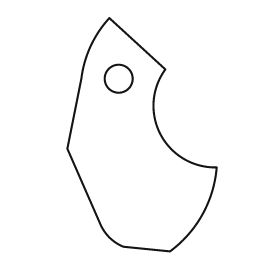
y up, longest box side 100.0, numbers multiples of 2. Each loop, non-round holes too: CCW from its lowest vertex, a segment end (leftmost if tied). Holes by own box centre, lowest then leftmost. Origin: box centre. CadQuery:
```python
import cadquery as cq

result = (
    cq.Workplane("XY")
    .moveTo(12.0, -50.0)
    .threePointArc((26.0, -34.0), (32.0, -14.0))
    .threePointArc((8.0, 0.0), (10.0, 28.0))
    .lineTo(-14.0, 50.0)
    .threePointArc((-22.0, 38.0), (-26.0, 24.0))
    .lineTo(-32.0, -6.0)
    .lineTo(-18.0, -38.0)
    .threePointArc((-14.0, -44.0), (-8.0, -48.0))
    .close()
    .moveTo(-10.0, 24.0)
    .circle(6.0)
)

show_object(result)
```